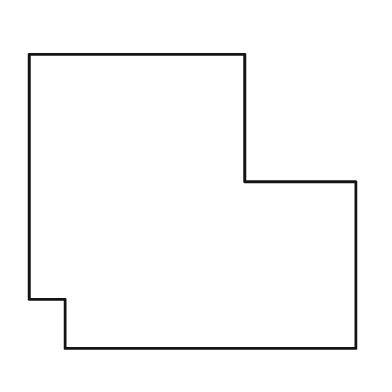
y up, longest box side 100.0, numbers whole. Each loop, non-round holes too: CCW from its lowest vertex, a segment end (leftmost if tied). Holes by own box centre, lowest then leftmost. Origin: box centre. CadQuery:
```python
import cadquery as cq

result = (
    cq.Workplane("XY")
    .moveTo(-39.0, -45.0)
    .lineTo(50.0, -45.0)
    .lineTo(50.0, 6.0)
    .lineTo(16.0, 6.0)
    .lineTo(16.0, 45.0)
    .lineTo(-50.0, 45.0)
    .lineTo(-50.0, -30.0)
    .lineTo(-39.0, -30.0)
    .close()
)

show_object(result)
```